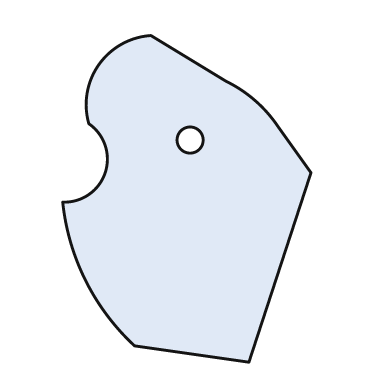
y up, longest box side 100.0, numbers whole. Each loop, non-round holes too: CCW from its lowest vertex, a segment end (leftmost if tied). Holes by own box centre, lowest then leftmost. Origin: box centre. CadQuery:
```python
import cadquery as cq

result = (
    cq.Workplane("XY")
    .moveTo(19.0, -50.0)
    .lineTo(38.0, 8.0)
    .lineTo(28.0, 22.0)
    .threePointArc((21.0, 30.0), (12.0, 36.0))
    .lineTo(-11.0, 50.0)
    .threePointArc((-27.0, 41.0), (-30.0, 23.0))
    .threePointArc((-25.0, 8.0), (-38.0, -1.0))
    .threePointArc((-31.0, -25.0), (-16.0, -45.0))
    .close()
    .moveTo(1.0, 18.0)
    .circle(4.0)
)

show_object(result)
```